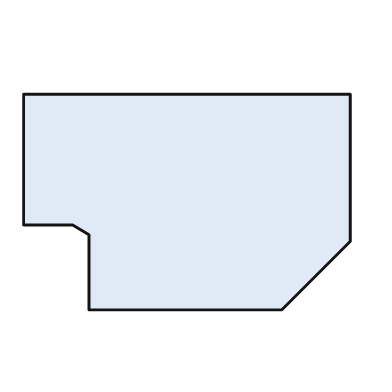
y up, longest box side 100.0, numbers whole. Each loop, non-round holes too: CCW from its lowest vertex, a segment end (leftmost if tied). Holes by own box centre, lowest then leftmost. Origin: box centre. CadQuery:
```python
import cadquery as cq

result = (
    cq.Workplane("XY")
    .moveTo(-30.0, -33.0)
    .lineTo(29.0, -33.0)
    .lineTo(50.0, -12.0)
    .lineTo(50.0, 33.0)
    .lineTo(-50.0, 33.0)
    .lineTo(-50.0, -7.0)
    .lineTo(-35.0, -7.0)
    .lineTo(-30.0, -10.0)
    .close()
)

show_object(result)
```